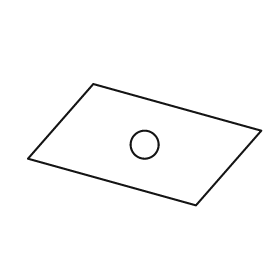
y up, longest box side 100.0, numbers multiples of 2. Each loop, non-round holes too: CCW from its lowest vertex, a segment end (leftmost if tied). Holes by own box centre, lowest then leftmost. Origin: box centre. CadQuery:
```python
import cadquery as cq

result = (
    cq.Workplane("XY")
    .moveTo(22.0, -26.0)
    .lineTo(50.0, 6.0)
    .lineTo(-22.0, 26.0)
    .lineTo(-50.0, -6.0)
    .close()
    .moveTo(0.0, 0.0)
    .circle(6.0)
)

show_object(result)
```